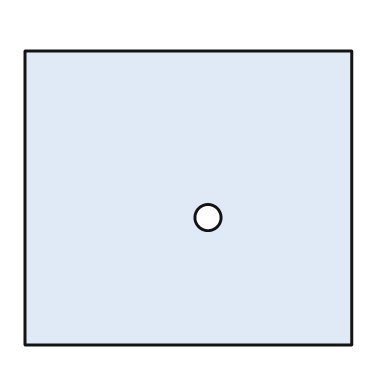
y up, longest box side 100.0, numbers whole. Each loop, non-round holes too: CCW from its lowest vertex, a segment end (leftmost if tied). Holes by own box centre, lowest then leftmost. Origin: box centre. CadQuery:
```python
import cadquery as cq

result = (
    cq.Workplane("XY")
    .moveTo(-50.0, -45.0)
    .lineTo(50.0, -45.0)
    .lineTo(50.0, 45.0)
    .lineTo(-50.0, 45.0)
    .close()
    .moveTo(6.0, -6.0)
    .circle(4.0)
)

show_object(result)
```